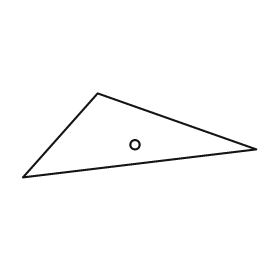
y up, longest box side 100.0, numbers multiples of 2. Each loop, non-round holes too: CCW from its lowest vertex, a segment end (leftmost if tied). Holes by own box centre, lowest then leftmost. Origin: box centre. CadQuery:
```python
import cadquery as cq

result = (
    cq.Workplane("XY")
    .moveTo(-50.0, -18.0)
    .lineTo(50.0, -6.0)
    .lineTo(-18.0, 18.0)
    .close()
    .moveTo(-2.0, -4.0)
    .circle(2.0)
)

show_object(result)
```